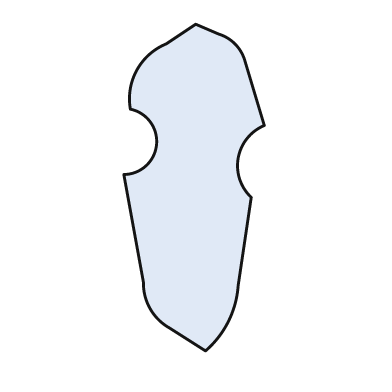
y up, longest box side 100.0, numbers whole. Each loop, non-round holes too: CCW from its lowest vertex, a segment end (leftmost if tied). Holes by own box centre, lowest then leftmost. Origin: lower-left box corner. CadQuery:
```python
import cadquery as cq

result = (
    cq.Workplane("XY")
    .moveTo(25.0, 0.0)
    .threePointArc((32.0, 9.0), (35.0, 20.0))
    .lineTo(39.0, 47.0)
    .threePointArc((35.0, 59.0), (43.0, 69.0))
    .lineTo(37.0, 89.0)
    .threePointArc((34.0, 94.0), (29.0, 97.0))
    .lineTo(22.0, 100.0)
    .lineTo(13.0, 94.0)
    .threePointArc((4.0, 86.0), (2.0, 74.0))
    .threePointArc((10.0, 63.0), (0.0, 54.0))
    .lineTo(6.0, 21.0)
    .threePointArc((8.0, 13.0), (14.0, 7.0))
    .close()
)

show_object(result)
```